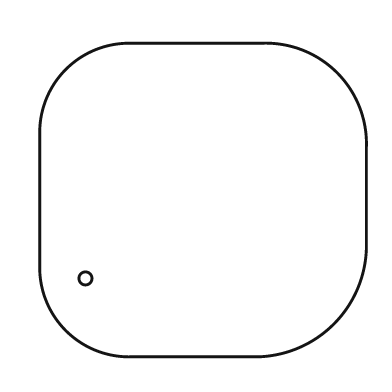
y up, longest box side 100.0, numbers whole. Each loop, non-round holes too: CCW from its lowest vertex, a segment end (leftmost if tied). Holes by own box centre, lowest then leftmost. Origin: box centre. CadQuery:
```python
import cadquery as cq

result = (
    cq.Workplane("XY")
    .moveTo(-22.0, -48.0)
    .lineTo(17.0, -48.0)
    .threePointArc((40.0, -38.0), (50.0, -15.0))
    .lineTo(50.0, 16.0)
    .threePointArc((41.0, 39.0), (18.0, 48.0))
    .lineTo(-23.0, 48.0)
    .threePointArc((-42.0, 40.0), (-50.0, 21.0))
    .lineTo(-50.0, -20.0)
    .threePointArc((-42.0, -40.0), (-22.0, -48.0))
    .close()
    .moveTo(-36.0, -24.0)
    .circle(2.0)
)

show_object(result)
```